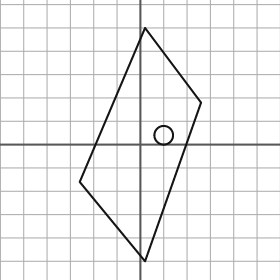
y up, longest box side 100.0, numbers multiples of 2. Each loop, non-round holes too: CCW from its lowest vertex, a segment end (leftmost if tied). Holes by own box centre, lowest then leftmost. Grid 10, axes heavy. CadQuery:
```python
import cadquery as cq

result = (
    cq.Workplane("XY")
    .moveTo(2.0, -50.0)
    .lineTo(26.0, 18.0)
    .lineTo(2.0, 50.0)
    .lineTo(-26.0, -16.0)
    .close()
    .moveTo(10.0, 4.0)
    .circle(4.0)
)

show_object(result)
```